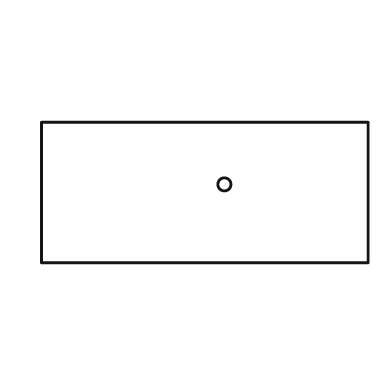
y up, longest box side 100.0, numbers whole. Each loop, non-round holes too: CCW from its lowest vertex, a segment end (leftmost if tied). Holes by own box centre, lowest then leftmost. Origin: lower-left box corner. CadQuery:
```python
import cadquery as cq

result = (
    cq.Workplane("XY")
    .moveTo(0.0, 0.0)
    .lineTo(100.0, 0.0)
    .lineTo(100.0, 43.0)
    .lineTo(0.0, 43.0)
    .close()
    .moveTo(56.0, 24.0)
    .circle(2.0)
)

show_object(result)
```